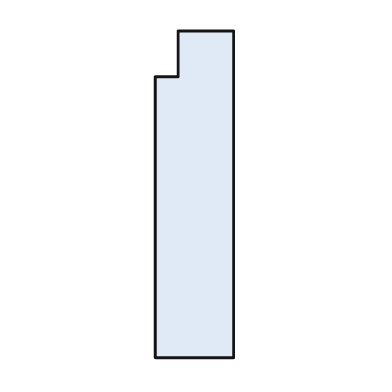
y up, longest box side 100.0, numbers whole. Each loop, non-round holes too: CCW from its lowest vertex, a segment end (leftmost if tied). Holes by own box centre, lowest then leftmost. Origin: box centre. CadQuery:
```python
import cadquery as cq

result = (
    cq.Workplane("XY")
    .moveTo(-12.0, -50.0)
    .lineTo(12.0, -50.0)
    .lineTo(12.0, 50.0)
    .lineTo(-5.0, 50.0)
    .lineTo(-5.0, 36.0)
    .lineTo(-12.0, 36.0)
    .close()
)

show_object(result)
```